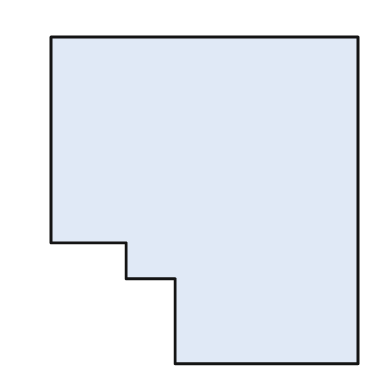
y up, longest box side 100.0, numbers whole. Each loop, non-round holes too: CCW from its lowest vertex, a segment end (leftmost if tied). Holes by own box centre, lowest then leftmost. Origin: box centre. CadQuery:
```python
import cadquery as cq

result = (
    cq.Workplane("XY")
    .moveTo(-9.0, -50.0)
    .lineTo(47.0, -50.0)
    .lineTo(47.0, 50.0)
    .lineTo(-47.0, 50.0)
    .lineTo(-47.0, -13.0)
    .lineTo(-24.0, -13.0)
    .lineTo(-24.0, -24.0)
    .lineTo(-9.0, -24.0)
    .close()
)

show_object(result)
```